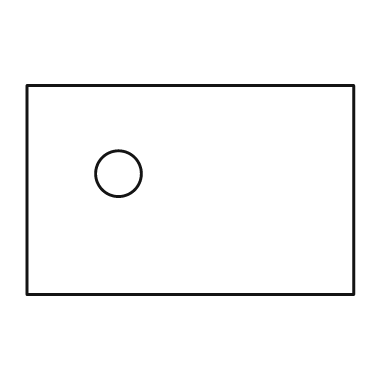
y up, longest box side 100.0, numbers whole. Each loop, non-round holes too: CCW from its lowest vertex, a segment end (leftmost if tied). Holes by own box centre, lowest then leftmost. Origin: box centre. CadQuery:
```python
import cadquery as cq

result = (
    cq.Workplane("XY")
    .moveTo(-50.0, -32.0)
    .lineTo(50.0, -32.0)
    .lineTo(50.0, 32.0)
    .lineTo(-50.0, 32.0)
    .close()
    .moveTo(-22.0, 5.0)
    .circle(7.0)
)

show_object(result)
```